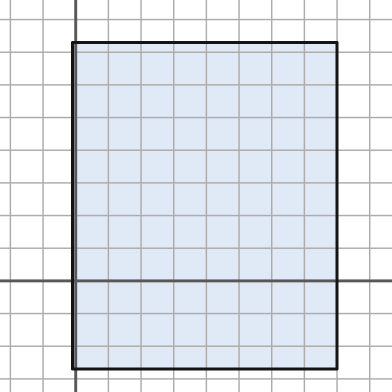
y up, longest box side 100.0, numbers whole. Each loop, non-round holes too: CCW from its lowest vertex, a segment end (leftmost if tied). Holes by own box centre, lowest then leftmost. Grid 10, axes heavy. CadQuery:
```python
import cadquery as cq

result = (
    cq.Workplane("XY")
    .moveTo(-1.0, -27.0)
    .lineTo(80.0, -27.0)
    .lineTo(80.0, 73.0)
    .lineTo(-1.0, 73.0)
    .close()
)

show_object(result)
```